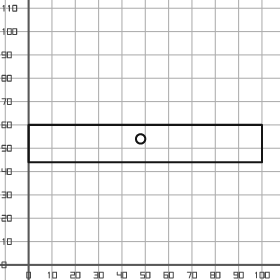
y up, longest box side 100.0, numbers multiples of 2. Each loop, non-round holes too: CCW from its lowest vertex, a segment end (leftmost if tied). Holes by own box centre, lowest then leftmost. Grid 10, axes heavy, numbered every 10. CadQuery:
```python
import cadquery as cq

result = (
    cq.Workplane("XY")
    .moveTo(0.0, 44.0)
    .lineTo(100.0, 44.0)
    .lineTo(100.0, 60.0)
    .lineTo(0.0, 60.0)
    .close()
    .moveTo(48.0, 54.0)
    .circle(2.0)
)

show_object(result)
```